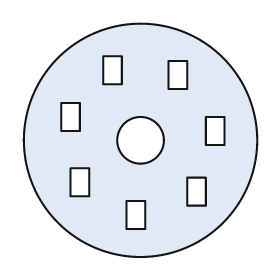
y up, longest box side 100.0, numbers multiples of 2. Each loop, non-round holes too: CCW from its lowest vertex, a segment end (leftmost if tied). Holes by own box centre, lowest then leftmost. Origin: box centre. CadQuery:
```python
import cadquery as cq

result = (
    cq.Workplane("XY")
    .moveTo(0.0, 0.0)
    .circle(50.0)
    .moveTo(-6.0, -38.0)
    .lineTo(2.0, -38.0)
    .lineTo(2.0, -26.0)
    .lineTo(-6.0, -26.0)
    .close()
    .moveTo(20.0, -28.0)
    .lineTo(28.0, -28.0)
    .lineTo(28.0, -16.0)
    .lineTo(20.0, -16.0)
    .close()
    .moveTo(-30.0, -24.0)
    .lineTo(-22.0, -24.0)
    .lineTo(-22.0, -12.0)
    .lineTo(-30.0, -12.0)
    .close()
    .moveTo(0.0, 0.0)
    .circle(10.0)
    .moveTo(28.0, -2.0)
    .lineTo(36.0, -2.0)
    .lineTo(36.0, 10.0)
    .lineTo(28.0, 10.0)
    .close()
    .moveTo(-34.0, 4.0)
    .lineTo(-26.0, 4.0)
    .lineTo(-26.0, 16.0)
    .lineTo(-34.0, 16.0)
    .close()
    .moveTo(12.0, 22.0)
    .lineTo(20.0, 22.0)
    .lineTo(20.0, 34.0)
    .lineTo(12.0, 34.0)
    .close()
    .moveTo(-16.0, 24.0)
    .lineTo(-8.0, 24.0)
    .lineTo(-8.0, 36.0)
    .lineTo(-16.0, 36.0)
    .close()
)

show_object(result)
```